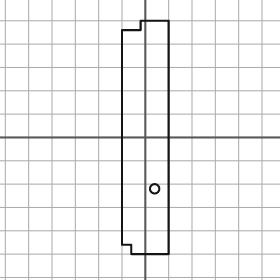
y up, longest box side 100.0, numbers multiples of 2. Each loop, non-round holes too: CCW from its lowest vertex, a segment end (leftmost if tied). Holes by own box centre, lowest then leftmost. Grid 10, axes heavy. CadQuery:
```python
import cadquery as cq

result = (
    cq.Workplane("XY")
    .moveTo(-6.0, -50.0)
    .lineTo(10.0, -50.0)
    .lineTo(10.0, 50.0)
    .lineTo(-2.0, 50.0)
    .lineTo(-2.0, 46.0)
    .lineTo(-10.0, 46.0)
    .lineTo(-10.0, -46.0)
    .lineTo(-6.0, -46.0)
    .close()
    .moveTo(4.0, -22.0)
    .circle(2.0)
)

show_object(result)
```